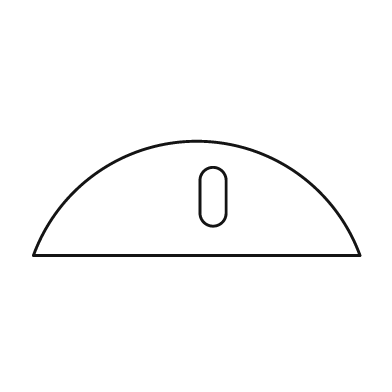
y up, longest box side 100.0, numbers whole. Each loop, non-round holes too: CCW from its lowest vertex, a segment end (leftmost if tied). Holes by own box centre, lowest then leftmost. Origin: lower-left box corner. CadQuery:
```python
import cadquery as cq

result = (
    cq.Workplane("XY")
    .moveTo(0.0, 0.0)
    .lineTo(100.0, 0.0)
    .threePointArc((50.0, 35.0), (0.0, 0.0))
    .close()
    .moveTo(51.0, 13.0)
    .threePointArc((55.0, 9.0), (59.0, 13.0))
    .lineTo(59.0, 23.0)
    .threePointArc((55.0, 27.0), (51.0, 23.0))
    .close()
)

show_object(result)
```